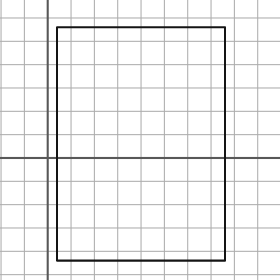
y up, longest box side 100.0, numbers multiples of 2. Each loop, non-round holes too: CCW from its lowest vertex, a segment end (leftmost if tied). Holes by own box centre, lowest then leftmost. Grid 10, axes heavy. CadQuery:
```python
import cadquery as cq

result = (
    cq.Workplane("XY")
    .moveTo(4.0, -44.0)
    .lineTo(76.0, -44.0)
    .lineTo(76.0, 56.0)
    .lineTo(4.0, 56.0)
    .close()
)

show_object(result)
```